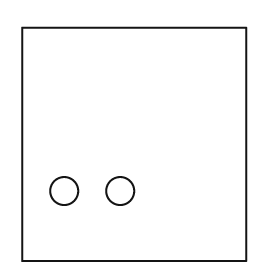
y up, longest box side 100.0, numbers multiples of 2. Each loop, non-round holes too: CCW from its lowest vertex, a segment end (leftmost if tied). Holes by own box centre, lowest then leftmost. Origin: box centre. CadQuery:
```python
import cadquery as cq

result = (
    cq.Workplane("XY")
    .moveTo(-48.0, -50.0)
    .lineTo(48.0, -50.0)
    .lineTo(48.0, 50.0)
    .lineTo(-48.0, 50.0)
    .close()
    .moveTo(-30.0, -20.0)
    .circle(6.0)
    .moveTo(-6.0, -20.0)
    .circle(6.0)
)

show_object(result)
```